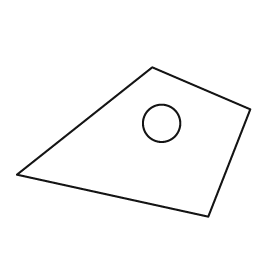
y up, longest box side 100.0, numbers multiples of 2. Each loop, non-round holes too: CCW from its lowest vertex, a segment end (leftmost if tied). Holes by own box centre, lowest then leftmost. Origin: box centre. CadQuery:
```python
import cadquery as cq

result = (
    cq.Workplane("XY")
    .moveTo(32.0, -32.0)
    .lineTo(50.0, 14.0)
    .lineTo(8.0, 32.0)
    .lineTo(-50.0, -14.0)
    .close()
    .moveTo(12.0, 8.0)
    .circle(8.0)
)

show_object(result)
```